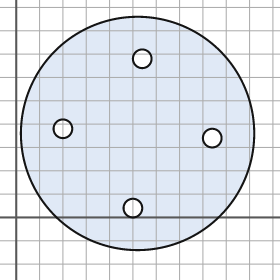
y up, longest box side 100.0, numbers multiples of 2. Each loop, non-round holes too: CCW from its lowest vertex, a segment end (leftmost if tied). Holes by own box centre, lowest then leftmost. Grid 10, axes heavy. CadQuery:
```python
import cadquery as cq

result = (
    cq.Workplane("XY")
    .moveTo(52.0, 36.0)
    .circle(50.0)
    .moveTo(50.0, 4.0)
    .circle(4.0)
    .moveTo(84.0, 34.0)
    .circle(4.0)
    .moveTo(20.0, 38.0)
    .circle(4.0)
    .moveTo(54.0, 68.0)
    .circle(4.0)
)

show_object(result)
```